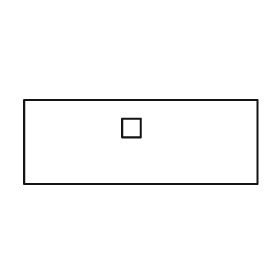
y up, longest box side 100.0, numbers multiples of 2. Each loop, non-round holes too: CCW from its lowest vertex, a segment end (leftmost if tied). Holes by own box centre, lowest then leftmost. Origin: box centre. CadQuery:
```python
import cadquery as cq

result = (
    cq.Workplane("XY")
    .moveTo(-50.0, -18.0)
    .lineTo(50.0, -18.0)
    .lineTo(50.0, 18.0)
    .lineTo(-50.0, 18.0)
    .close()
    .moveTo(-8.0, 2.0)
    .lineTo(0.0, 2.0)
    .lineTo(0.0, 10.0)
    .lineTo(-8.0, 10.0)
    .close()
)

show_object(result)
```